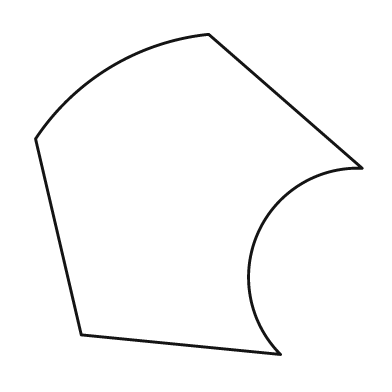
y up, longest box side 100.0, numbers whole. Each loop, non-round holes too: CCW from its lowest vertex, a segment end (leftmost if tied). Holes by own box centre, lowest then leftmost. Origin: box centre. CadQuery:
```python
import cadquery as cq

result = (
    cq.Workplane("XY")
    .moveTo(25.0, -49.0)
    .threePointArc((18.0, -12.0), (50.0, 8.0))
    .lineTo(3.0, 49.0)
    .threePointArc((-27.0, 39.0), (-50.0, 17.0))
    .lineTo(-36.0, -43.0)
    .close()
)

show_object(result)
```